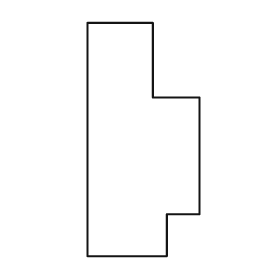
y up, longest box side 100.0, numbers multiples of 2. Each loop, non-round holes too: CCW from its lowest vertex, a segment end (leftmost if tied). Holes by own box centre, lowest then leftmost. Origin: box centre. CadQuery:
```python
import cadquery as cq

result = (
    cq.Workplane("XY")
    .moveTo(-24.0, -50.0)
    .lineTo(10.0, -50.0)
    .lineTo(10.0, -32.0)
    .lineTo(24.0, -32.0)
    .lineTo(24.0, 18.0)
    .lineTo(4.0, 18.0)
    .lineTo(4.0, 50.0)
    .lineTo(-24.0, 50.0)
    .close()
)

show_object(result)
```